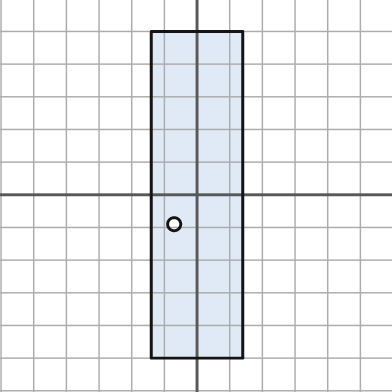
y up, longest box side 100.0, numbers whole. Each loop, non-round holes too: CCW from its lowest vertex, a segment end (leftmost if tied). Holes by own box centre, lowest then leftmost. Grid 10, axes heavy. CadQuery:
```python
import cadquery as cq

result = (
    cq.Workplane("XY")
    .moveTo(-14.0, -50.0)
    .lineTo(14.0, -50.0)
    .lineTo(14.0, 50.0)
    .lineTo(-14.0, 50.0)
    .close()
    .moveTo(-7.0, -9.0)
    .circle(2.0)
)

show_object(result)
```